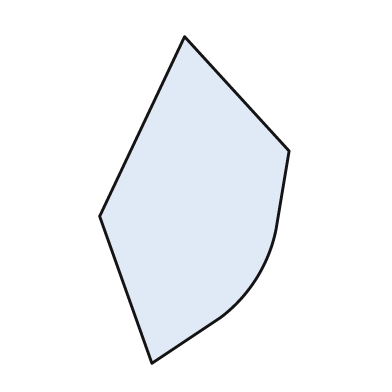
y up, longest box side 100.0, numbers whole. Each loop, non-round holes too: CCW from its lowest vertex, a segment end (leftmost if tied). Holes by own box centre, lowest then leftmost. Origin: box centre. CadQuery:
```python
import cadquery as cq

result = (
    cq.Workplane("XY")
    .moveTo(-13.0, -50.0)
    .lineTo(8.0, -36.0)
    .threePointArc((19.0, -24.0), (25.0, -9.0))
    .lineTo(29.0, 15.0)
    .lineTo(-3.0, 50.0)
    .lineTo(-29.0, -5.0)
    .close()
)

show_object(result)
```